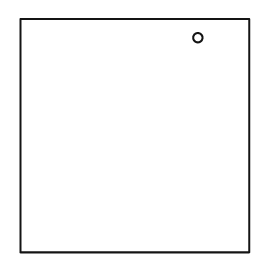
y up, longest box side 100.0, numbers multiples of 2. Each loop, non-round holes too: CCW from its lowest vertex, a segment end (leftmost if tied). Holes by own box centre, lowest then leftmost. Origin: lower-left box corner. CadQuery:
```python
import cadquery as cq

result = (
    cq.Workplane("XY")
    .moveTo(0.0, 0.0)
    .lineTo(98.0, 0.0)
    .lineTo(98.0, 100.0)
    .lineTo(0.0, 100.0)
    .close()
    .moveTo(76.0, 92.0)
    .circle(2.0)
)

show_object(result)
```